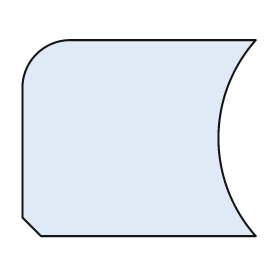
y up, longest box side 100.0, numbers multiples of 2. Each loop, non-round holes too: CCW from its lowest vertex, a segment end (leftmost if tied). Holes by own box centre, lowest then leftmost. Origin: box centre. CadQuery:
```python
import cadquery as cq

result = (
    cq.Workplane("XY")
    .moveTo(-42.0, -42.0)
    .lineTo(50.0, -42.0)
    .threePointArc((34.0, 0.0), (50.0, 42.0))
    .lineTo(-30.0, 42.0)
    .threePointArc((-44.0, 36.0), (-50.0, 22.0))
    .lineTo(-50.0, -34.0)
    .close()
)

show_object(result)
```